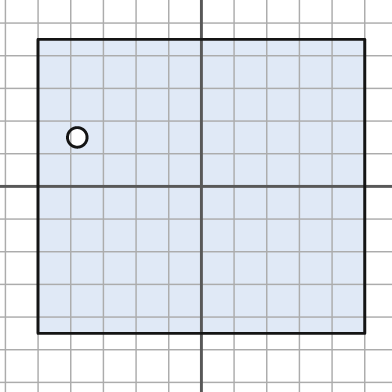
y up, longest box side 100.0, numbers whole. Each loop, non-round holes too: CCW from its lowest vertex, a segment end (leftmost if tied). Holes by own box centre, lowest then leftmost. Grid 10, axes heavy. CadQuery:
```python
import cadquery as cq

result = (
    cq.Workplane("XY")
    .moveTo(-50.0, -45.0)
    .lineTo(50.0, -45.0)
    .lineTo(50.0, 45.0)
    .lineTo(-50.0, 45.0)
    .close()
    .moveTo(-38.0, 15.0)
    .circle(3.0)
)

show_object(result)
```